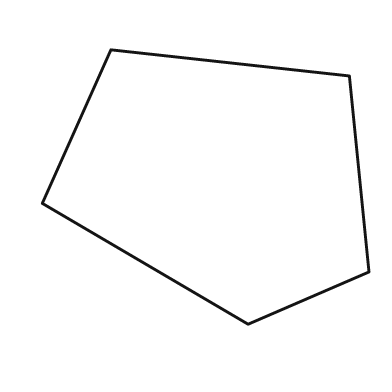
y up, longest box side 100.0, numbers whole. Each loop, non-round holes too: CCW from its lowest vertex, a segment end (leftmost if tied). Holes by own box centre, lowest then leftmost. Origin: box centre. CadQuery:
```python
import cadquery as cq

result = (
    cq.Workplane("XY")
    .moveTo(13.0, -42.0)
    .lineTo(50.0, -26.0)
    .lineTo(44.0, 34.0)
    .lineTo(-29.0, 42.0)
    .lineTo(-50.0, -5.0)
    .close()
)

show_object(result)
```